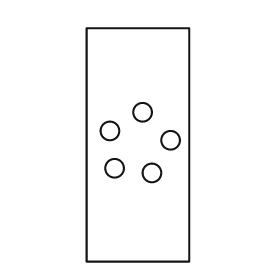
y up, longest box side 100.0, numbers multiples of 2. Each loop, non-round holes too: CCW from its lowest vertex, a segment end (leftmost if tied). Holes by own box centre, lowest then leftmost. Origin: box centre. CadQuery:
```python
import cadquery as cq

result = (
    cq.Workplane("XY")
    .moveTo(-22.0, -50.0)
    .lineTo(22.0, -50.0)
    .lineTo(22.0, 50.0)
    .lineTo(-22.0, 50.0)
    .close()
    .moveTo(6.0, -12.0)
    .circle(4.0)
    .moveTo(-10.0, -10.0)
    .circle(4.0)
    .moveTo(14.0, 2.0)
    .circle(4.0)
    .moveTo(-12.0, 6.0)
    .circle(4.0)
    .moveTo(2.0, 14.0)
    .circle(4.0)
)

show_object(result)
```